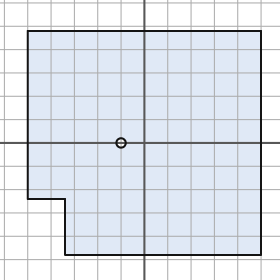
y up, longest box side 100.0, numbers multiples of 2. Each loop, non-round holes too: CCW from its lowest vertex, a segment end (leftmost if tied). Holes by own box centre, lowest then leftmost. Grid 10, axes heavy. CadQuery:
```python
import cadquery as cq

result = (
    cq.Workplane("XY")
    .moveTo(-34.0, -48.0)
    .lineTo(50.0, -48.0)
    .lineTo(50.0, 48.0)
    .lineTo(-50.0, 48.0)
    .lineTo(-50.0, -24.0)
    .lineTo(-34.0, -24.0)
    .close()
    .moveTo(-10.0, 0.0)
    .circle(2.0)
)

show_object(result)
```